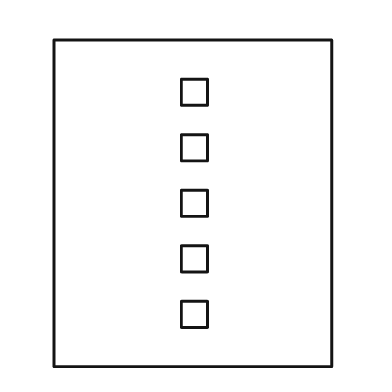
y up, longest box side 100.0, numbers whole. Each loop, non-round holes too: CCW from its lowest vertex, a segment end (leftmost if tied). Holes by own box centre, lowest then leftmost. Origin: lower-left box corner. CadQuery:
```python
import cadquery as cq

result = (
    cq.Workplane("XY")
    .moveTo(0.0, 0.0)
    .lineTo(85.0, 0.0)
    .lineTo(85.0, 100.0)
    .lineTo(0.0, 100.0)
    .close()
    .moveTo(39.0, 12.0)
    .lineTo(47.0, 12.0)
    .lineTo(47.0, 20.0)
    .lineTo(39.0, 20.0)
    .close()
    .moveTo(39.0, 29.0)
    .lineTo(47.0, 29.0)
    .lineTo(47.0, 37.0)
    .lineTo(39.0, 37.0)
    .close()
    .moveTo(39.0, 46.0)
    .lineTo(47.0, 46.0)
    .lineTo(47.0, 54.0)
    .lineTo(39.0, 54.0)
    .close()
    .moveTo(39.0, 63.0)
    .lineTo(47.0, 63.0)
    .lineTo(47.0, 71.0)
    .lineTo(39.0, 71.0)
    .close()
    .moveTo(39.0, 80.0)
    .lineTo(47.0, 80.0)
    .lineTo(47.0, 88.0)
    .lineTo(39.0, 88.0)
    .close()
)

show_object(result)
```